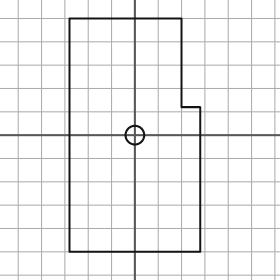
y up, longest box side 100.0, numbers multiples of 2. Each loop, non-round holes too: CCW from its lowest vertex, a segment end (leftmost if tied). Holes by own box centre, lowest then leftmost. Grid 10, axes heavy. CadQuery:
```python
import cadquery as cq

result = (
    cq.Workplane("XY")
    .moveTo(-28.0, -50.0)
    .lineTo(28.0, -50.0)
    .lineTo(28.0, 12.0)
    .lineTo(20.0, 12.0)
    .lineTo(20.0, 50.0)
    .lineTo(-28.0, 50.0)
    .close()
    .moveTo(0.0, 0.0)
    .circle(4.0)
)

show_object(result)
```